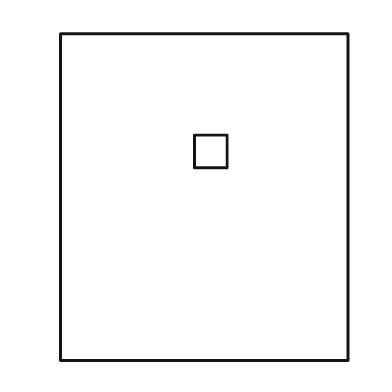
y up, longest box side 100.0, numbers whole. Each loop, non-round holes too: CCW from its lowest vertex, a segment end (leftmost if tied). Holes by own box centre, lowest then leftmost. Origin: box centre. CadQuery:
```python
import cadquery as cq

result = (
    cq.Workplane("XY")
    .moveTo(-44.0, -50.0)
    .lineTo(44.0, -50.0)
    .lineTo(44.0, 50.0)
    .lineTo(-44.0, 50.0)
    .close()
    .moveTo(-3.0, 9.0)
    .lineTo(7.0, 9.0)
    .lineTo(7.0, 19.0)
    .lineTo(-3.0, 19.0)
    .close()
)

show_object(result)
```